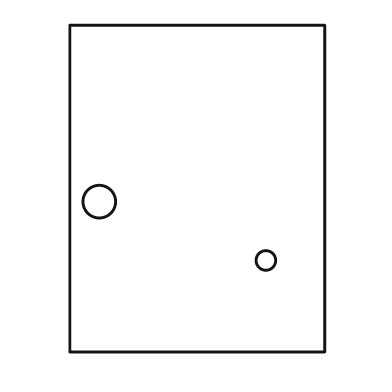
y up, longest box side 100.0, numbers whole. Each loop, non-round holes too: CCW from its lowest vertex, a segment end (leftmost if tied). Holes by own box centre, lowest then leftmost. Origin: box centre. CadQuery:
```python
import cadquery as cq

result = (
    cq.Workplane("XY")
    .moveTo(-39.0, -50.0)
    .lineTo(39.0, -50.0)
    .lineTo(39.0, 50.0)
    .lineTo(-39.0, 50.0)
    .close()
    .moveTo(21.0, -22.0)
    .circle(3.0)
    .moveTo(-30.0, -4.0)
    .circle(5.0)
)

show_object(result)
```